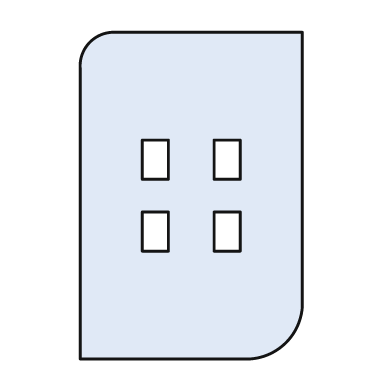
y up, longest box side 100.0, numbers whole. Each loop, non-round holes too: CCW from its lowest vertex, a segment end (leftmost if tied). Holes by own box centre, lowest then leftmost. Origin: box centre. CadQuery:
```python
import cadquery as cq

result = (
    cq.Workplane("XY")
    .moveTo(-34.0, -50.0)
    .lineTo(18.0, -50.0)
    .threePointArc((29.0, -45.0), (34.0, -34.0))
    .lineTo(34.0, 50.0)
    .lineTo(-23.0, 50.0)
    .threePointArc((-31.0, 47.0), (-34.0, 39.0))
    .close()
    .moveTo(-15.0, -17.0)
    .lineTo(-7.0, -17.0)
    .lineTo(-7.0, -5.0)
    .lineTo(-15.0, -5.0)
    .close()
    .moveTo(7.0, -17.0)
    .lineTo(15.0, -17.0)
    .lineTo(15.0, -5.0)
    .lineTo(7.0, -5.0)
    .close()
    .moveTo(-15.0, 5.0)
    .lineTo(-7.0, 5.0)
    .lineTo(-7.0, 17.0)
    .lineTo(-15.0, 17.0)
    .close()
    .moveTo(7.0, 5.0)
    .lineTo(15.0, 5.0)
    .lineTo(15.0, 17.0)
    .lineTo(7.0, 17.0)
    .close()
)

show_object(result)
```